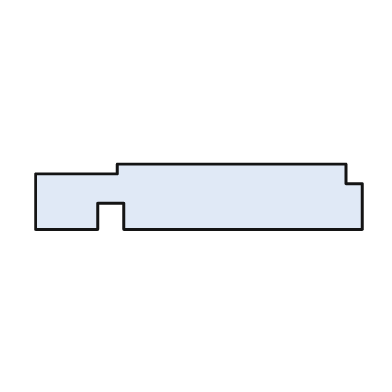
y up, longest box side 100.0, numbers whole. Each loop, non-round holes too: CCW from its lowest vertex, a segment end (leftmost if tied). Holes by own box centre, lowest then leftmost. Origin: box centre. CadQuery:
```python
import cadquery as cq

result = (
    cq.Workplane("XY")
    .moveTo(-50.0, -10.0)
    .lineTo(-31.0, -10.0)
    .lineTo(-31.0, -2.0)
    .lineTo(-23.0, -2.0)
    .lineTo(-23.0, -10.0)
    .lineTo(50.0, -10.0)
    .lineTo(50.0, 4.0)
    .lineTo(45.0, 4.0)
    .lineTo(45.0, 10.0)
    .lineTo(-25.0, 10.0)
    .lineTo(-25.0, 7.0)
    .lineTo(-50.0, 7.0)
    .close()
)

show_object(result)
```